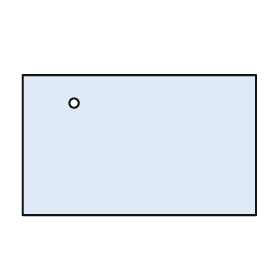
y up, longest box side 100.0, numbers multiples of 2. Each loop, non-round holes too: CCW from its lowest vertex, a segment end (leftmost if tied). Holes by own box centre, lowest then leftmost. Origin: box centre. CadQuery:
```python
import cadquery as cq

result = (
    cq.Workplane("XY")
    .moveTo(-50.0, -30.0)
    .lineTo(50.0, -30.0)
    .lineTo(50.0, 30.0)
    .lineTo(-50.0, 30.0)
    .close()
    .moveTo(-28.0, 18.0)
    .circle(2.0)
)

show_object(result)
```